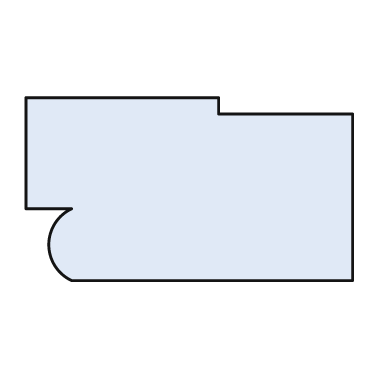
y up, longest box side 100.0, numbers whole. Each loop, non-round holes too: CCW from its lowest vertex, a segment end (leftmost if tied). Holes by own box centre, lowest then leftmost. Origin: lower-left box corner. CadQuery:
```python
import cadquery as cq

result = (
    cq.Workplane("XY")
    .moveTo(14.0, 0.0)
    .lineTo(100.0, 0.0)
    .lineTo(100.0, 51.0)
    .lineTo(59.0, 51.0)
    .lineTo(59.0, 56.0)
    .lineTo(0.0, 56.0)
    .lineTo(0.0, 22.0)
    .lineTo(14.0, 22.0)
    .threePointArc((7.0, 11.0), (14.0, 0.0))
    .close()
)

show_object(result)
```